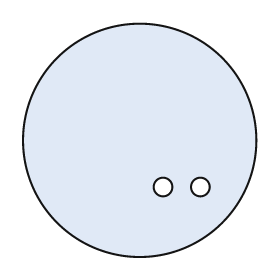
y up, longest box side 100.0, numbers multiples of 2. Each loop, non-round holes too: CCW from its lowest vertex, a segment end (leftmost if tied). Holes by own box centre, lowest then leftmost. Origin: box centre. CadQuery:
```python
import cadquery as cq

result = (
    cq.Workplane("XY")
    .moveTo(0.0, 0.0)
    .circle(50.0)
    .moveTo(10.0, -20.0)
    .circle(4.0)
    .moveTo(26.0, -20.0)
    .circle(4.0)
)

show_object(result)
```